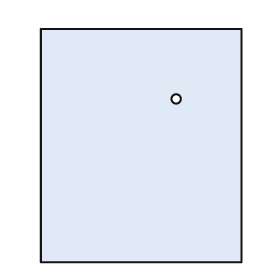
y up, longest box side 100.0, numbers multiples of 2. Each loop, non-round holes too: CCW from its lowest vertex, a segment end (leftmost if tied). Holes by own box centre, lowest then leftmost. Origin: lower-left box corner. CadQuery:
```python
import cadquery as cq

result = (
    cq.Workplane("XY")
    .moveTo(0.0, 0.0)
    .lineTo(86.0, 0.0)
    .lineTo(86.0, 100.0)
    .lineTo(0.0, 100.0)
    .close()
    .moveTo(58.0, 70.0)
    .circle(2.0)
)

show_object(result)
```